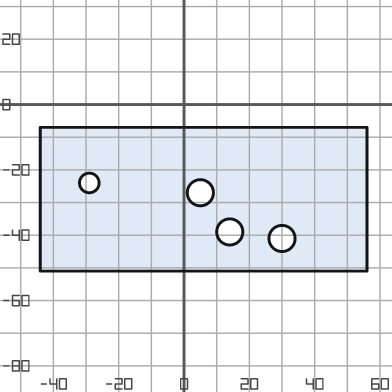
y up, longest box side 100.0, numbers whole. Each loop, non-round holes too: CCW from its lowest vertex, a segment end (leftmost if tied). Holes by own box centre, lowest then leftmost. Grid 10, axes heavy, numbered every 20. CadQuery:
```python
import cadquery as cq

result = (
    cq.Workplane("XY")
    .moveTo(-44.0, -51.0)
    .lineTo(56.0, -51.0)
    .lineTo(56.0, -7.0)
    .lineTo(-44.0, -7.0)
    .close()
    .moveTo(30.0, -41.0)
    .circle(4.0)
    .moveTo(14.0, -39.0)
    .circle(4.0)
    .moveTo(5.0, -27.0)
    .circle(4.0)
    .moveTo(-29.0, -24.0)
    .circle(3.0)
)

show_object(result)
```